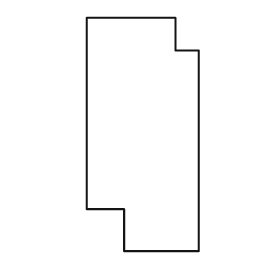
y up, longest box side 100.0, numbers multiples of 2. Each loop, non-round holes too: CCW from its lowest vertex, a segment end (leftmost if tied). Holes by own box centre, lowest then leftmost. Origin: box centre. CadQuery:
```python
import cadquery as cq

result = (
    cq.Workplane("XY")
    .moveTo(-8.0, -50.0)
    .lineTo(24.0, -50.0)
    .lineTo(24.0, 36.0)
    .lineTo(14.0, 36.0)
    .lineTo(14.0, 50.0)
    .lineTo(-24.0, 50.0)
    .lineTo(-24.0, -32.0)
    .lineTo(-8.0, -32.0)
    .close()
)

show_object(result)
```